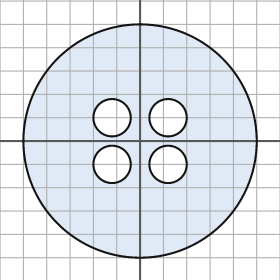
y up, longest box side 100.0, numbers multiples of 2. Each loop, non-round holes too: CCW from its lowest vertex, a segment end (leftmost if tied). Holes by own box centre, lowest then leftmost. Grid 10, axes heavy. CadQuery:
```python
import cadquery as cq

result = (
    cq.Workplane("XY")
    .moveTo(0.0, 0.0)
    .circle(50.0)
    .moveTo(-12.0, -10.0)
    .circle(8.0)
    .moveTo(12.0, -10.0)
    .circle(8.0)
    .moveTo(-12.0, 10.0)
    .circle(8.0)
    .moveTo(12.0, 10.0)
    .circle(8.0)
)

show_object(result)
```